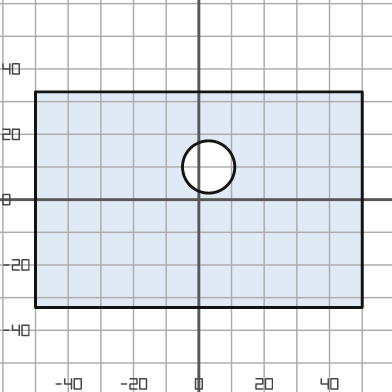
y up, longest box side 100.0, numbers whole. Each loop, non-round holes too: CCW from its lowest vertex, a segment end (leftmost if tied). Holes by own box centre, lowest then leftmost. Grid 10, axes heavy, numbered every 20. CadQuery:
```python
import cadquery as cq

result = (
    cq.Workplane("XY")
    .moveTo(-50.0, -33.0)
    .lineTo(50.0, -33.0)
    .lineTo(50.0, 33.0)
    .lineTo(-50.0, 33.0)
    .close()
    .moveTo(3.0, 10.0)
    .circle(8.0)
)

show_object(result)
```